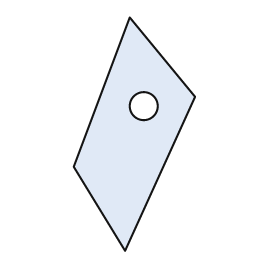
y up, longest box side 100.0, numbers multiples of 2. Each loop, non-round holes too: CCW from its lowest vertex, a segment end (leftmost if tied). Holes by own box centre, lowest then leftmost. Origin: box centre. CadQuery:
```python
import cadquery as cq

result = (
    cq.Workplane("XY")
    .moveTo(-4.0, -50.0)
    .lineTo(26.0, 16.0)
    .lineTo(-2.0, 50.0)
    .lineTo(-26.0, -14.0)
    .close()
    .moveTo(4.0, 12.0)
    .circle(6.0)
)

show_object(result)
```